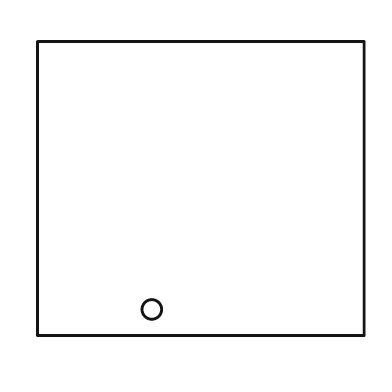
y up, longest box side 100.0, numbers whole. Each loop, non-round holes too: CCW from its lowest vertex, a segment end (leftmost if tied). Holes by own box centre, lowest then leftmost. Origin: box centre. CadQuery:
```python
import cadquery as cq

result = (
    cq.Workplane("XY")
    .moveTo(-50.0, -45.0)
    .lineTo(50.0, -45.0)
    .lineTo(50.0, 45.0)
    .lineTo(-50.0, 45.0)
    .close()
    .moveTo(-15.0, -37.0)
    .circle(3.0)
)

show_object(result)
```